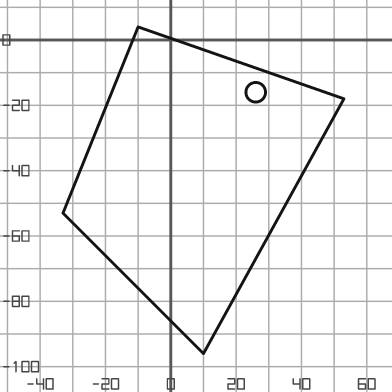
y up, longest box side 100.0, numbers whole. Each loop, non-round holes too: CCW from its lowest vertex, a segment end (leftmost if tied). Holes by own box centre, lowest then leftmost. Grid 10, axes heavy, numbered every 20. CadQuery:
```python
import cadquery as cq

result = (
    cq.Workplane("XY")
    .moveTo(10.0, -96.0)
    .lineTo(53.0, -18.0)
    .lineTo(-10.0, 4.0)
    .lineTo(-33.0, -53.0)
    .close()
    .moveTo(26.0, -16.0)
    .circle(3.0)
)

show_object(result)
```